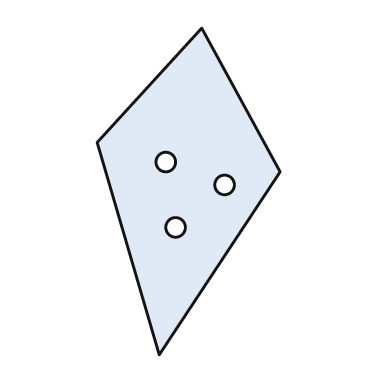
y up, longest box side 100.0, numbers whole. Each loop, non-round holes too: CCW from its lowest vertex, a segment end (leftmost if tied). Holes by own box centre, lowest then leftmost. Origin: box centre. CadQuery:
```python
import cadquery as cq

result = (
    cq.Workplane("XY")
    .moveTo(-9.0, -50.0)
    .lineTo(28.0, 6.0)
    .lineTo(4.0, 50.0)
    .lineTo(-28.0, 15.0)
    .close()
    .moveTo(-4.0, -11.0)
    .circle(3.0)
    .moveTo(11.0, 2.0)
    .circle(3.0)
    .moveTo(-7.0, 9.0)
    .circle(3.0)
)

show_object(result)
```